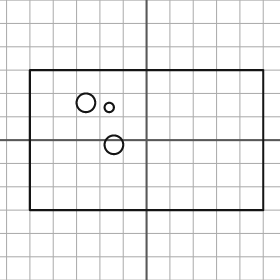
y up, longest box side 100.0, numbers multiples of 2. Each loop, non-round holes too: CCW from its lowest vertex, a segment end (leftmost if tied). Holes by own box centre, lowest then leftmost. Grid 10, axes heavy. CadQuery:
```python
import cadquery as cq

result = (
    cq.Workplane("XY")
    .moveTo(-50.0, -30.0)
    .lineTo(50.0, -30.0)
    .lineTo(50.0, 30.0)
    .lineTo(-50.0, 30.0)
    .close()
    .moveTo(-14.0, -2.0)
    .circle(4.0)
    .moveTo(-16.0, 14.0)
    .circle(2.0)
    .moveTo(-26.0, 16.0)
    .circle(4.0)
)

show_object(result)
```